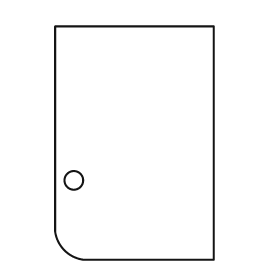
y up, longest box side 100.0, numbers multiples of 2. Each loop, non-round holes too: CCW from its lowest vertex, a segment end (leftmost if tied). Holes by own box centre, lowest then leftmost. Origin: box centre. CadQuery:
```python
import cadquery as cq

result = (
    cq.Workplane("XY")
    .moveTo(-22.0, -50.0)
    .lineTo(34.0, -50.0)
    .lineTo(34.0, 50.0)
    .lineTo(-34.0, 50.0)
    .lineTo(-34.0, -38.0)
    .threePointArc((-30.0, -46.0), (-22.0, -50.0))
    .close()
    .moveTo(-26.0, -16.0)
    .circle(4.0)
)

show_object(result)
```